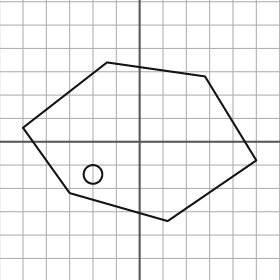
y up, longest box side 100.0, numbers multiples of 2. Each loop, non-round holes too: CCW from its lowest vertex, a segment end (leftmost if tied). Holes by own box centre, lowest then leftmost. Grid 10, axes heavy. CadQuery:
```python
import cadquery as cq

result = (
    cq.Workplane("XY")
    .moveTo(12.0, -34.0)
    .lineTo(50.0, -8.0)
    .lineTo(28.0, 28.0)
    .lineTo(-14.0, 34.0)
    .lineTo(-50.0, 6.0)
    .lineTo(-30.0, -22.0)
    .close()
    .moveTo(-20.0, -14.0)
    .circle(4.0)
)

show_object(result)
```